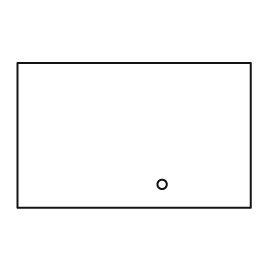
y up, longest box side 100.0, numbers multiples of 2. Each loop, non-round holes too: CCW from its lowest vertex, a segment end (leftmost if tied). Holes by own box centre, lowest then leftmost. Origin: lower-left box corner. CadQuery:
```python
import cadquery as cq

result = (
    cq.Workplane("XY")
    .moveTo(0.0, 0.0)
    .lineTo(100.0, 0.0)
    .lineTo(100.0, 62.0)
    .lineTo(0.0, 62.0)
    .close()
    .moveTo(62.0, 10.0)
    .circle(2.0)
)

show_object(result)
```